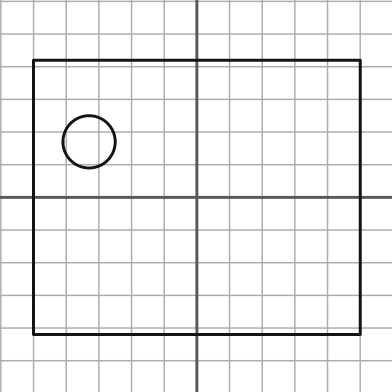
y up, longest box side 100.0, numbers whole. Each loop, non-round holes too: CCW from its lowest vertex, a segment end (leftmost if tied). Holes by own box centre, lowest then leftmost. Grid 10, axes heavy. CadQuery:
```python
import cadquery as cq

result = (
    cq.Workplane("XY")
    .moveTo(-50.0, -42.0)
    .lineTo(50.0, -42.0)
    .lineTo(50.0, 42.0)
    .lineTo(-50.0, 42.0)
    .close()
    .moveTo(-33.0, 17.0)
    .circle(8.0)
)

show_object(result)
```